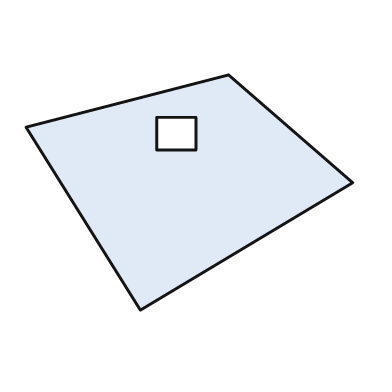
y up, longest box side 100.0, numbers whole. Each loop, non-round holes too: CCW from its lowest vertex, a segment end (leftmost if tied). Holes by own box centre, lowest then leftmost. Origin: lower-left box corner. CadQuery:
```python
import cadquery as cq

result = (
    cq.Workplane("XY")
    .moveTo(35.0, 0.0)
    .lineTo(100.0, 39.0)
    .lineTo(62.0, 72.0)
    .lineTo(0.0, 56.0)
    .close()
    .moveTo(40.0, 49.0)
    .lineTo(52.0, 49.0)
    .lineTo(52.0, 59.0)
    .lineTo(40.0, 59.0)
    .close()
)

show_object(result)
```